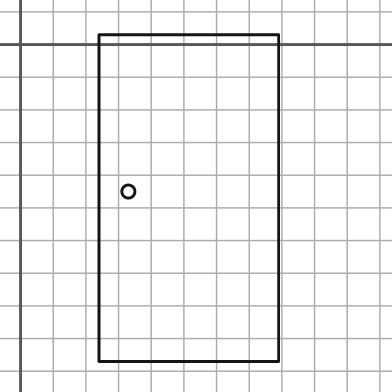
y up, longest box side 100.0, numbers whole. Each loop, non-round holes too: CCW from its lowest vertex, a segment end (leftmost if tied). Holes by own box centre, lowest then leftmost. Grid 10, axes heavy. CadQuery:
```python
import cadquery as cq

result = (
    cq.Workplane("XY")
    .moveTo(24.0, -97.0)
    .lineTo(79.0, -97.0)
    .lineTo(79.0, 3.0)
    .lineTo(24.0, 3.0)
    .close()
    .moveTo(33.0, -45.0)
    .circle(2.0)
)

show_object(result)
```